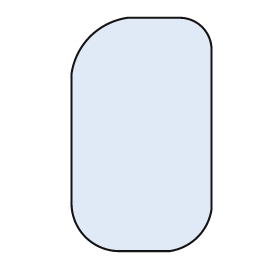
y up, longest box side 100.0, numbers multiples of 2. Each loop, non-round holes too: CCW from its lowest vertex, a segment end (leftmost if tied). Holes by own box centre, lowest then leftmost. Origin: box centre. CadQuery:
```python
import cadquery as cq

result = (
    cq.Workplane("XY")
    .moveTo(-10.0, -50.0)
    .lineTo(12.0, -50.0)
    .threePointArc((24.0, -44.0), (30.0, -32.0))
    .lineTo(30.0, 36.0)
    .threePointArc((26.0, 46.0), (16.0, 50.0))
    .lineTo(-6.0, 50.0)
    .threePointArc((-22.0, 42.0), (-30.0, 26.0))
    .lineTo(-30.0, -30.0)
    .threePointArc((-24.0, -44.0), (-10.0, -50.0))
    .close()
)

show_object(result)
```